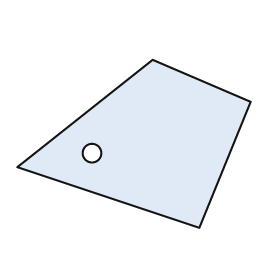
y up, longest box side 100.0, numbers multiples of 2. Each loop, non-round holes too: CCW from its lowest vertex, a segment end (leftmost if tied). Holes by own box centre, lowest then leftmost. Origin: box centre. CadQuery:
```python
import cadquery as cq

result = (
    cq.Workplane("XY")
    .moveTo(28.0, -36.0)
    .lineTo(50.0, 18.0)
    .lineTo(8.0, 36.0)
    .lineTo(-50.0, -10.0)
    .close()
    .moveTo(-18.0, -4.0)
    .circle(4.0)
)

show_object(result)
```